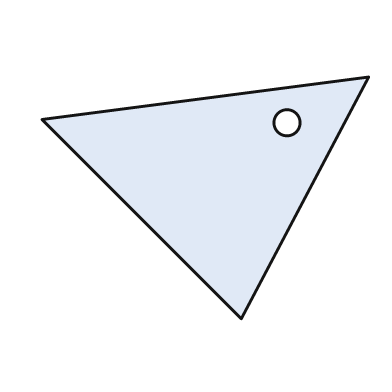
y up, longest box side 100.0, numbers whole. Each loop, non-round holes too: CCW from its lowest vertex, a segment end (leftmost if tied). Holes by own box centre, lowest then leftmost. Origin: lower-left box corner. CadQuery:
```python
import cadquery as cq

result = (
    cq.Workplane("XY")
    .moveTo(61.0, 0.0)
    .lineTo(100.0, 74.0)
    .lineTo(0.0, 61.0)
    .close()
    .moveTo(75.0, 60.0)
    .circle(4.0)
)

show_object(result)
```